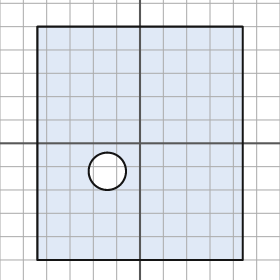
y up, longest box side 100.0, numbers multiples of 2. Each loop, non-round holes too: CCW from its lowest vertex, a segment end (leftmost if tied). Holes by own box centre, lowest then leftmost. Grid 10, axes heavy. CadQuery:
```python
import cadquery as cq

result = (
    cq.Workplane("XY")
    .moveTo(-44.0, -50.0)
    .lineTo(44.0, -50.0)
    .lineTo(44.0, 50.0)
    .lineTo(-44.0, 50.0)
    .close()
    .moveTo(-14.0, -12.0)
    .circle(8.0)
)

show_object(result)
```